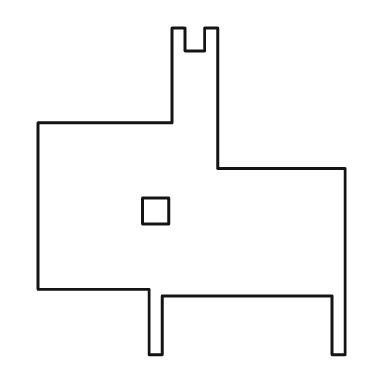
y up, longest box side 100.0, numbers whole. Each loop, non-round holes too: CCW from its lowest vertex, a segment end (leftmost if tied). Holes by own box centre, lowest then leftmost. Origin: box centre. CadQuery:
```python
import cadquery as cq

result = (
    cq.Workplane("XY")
    .moveTo(-13.0, -50.0)
    .lineTo(-9.0, -50.0)
    .lineTo(-9.0, -32.0)
    .lineTo(43.0, -32.0)
    .lineTo(43.0, -50.0)
    .lineTo(47.0, -50.0)
    .lineTo(47.0, 7.0)
    .lineTo(8.0, 7.0)
    .lineTo(8.0, 50.0)
    .lineTo(4.0, 50.0)
    .lineTo(4.0, 43.0)
    .lineTo(-2.0, 43.0)
    .lineTo(-2.0, 50.0)
    .lineTo(-6.0, 50.0)
    .lineTo(-6.0, 21.0)
    .lineTo(-47.0, 21.0)
    .lineTo(-47.0, -30.0)
    .lineTo(-13.0, -30.0)
    .close()
    .moveTo(-15.0, -10.0)
    .lineTo(-7.0, -10.0)
    .lineTo(-7.0, -2.0)
    .lineTo(-15.0, -2.0)
    .close()
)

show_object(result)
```